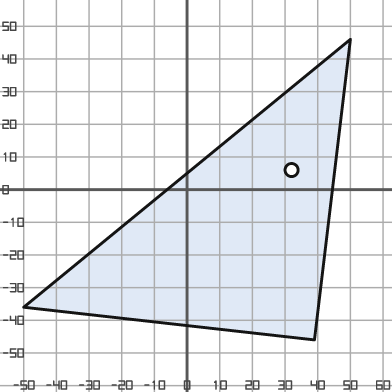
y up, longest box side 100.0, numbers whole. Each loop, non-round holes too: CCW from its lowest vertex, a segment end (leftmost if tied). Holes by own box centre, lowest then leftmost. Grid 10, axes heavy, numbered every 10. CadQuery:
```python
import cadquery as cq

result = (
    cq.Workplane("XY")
    .moveTo(39.0, -46.0)
    .lineTo(50.0, 46.0)
    .lineTo(-50.0, -36.0)
    .close()
    .moveTo(32.0, 6.0)
    .circle(2.0)
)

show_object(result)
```